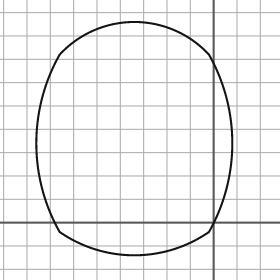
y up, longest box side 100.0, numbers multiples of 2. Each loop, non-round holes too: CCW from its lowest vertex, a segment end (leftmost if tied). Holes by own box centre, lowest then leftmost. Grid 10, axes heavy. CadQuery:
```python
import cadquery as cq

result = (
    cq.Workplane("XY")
    .moveTo(-66.0, -4.0)
    .threePointArc((-34.0, -14.0), (-2.0, -4.0))
    .threePointArc((8.0, 34.0), (-2.0, 72.0))
    .threePointArc((-34.0, 86.0), (-66.0, 72.0))
    .threePointArc((-76.0, 34.0), (-66.0, -4.0))
    .close()
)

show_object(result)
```